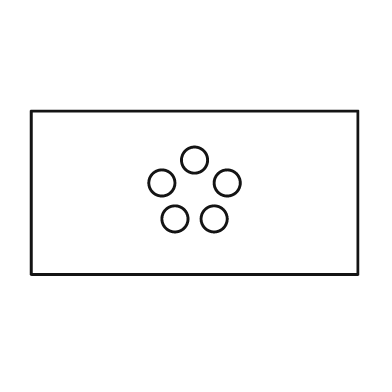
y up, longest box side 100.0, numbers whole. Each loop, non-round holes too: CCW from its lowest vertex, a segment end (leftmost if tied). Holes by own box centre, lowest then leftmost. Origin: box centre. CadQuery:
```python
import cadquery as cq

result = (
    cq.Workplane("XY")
    .moveTo(-50.0, -25.0)
    .lineTo(50.0, -25.0)
    .lineTo(50.0, 25.0)
    .lineTo(-50.0, 25.0)
    .close()
    .moveTo(-6.0, -8.0)
    .circle(4.0)
    .moveTo(6.0, -8.0)
    .circle(4.0)
    .moveTo(-10.0, 3.0)
    .circle(4.0)
    .moveTo(10.0, 3.0)
    .circle(4.0)
    .moveTo(0.0, 10.0)
    .circle(4.0)
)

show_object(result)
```